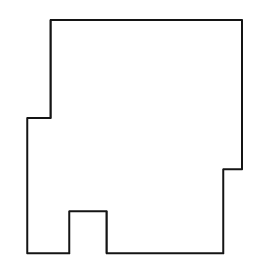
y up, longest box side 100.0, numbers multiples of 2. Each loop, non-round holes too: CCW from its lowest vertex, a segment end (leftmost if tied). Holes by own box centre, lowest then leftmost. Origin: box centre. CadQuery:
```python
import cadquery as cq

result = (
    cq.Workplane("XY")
    .moveTo(-46.0, -50.0)
    .lineTo(-28.0, -50.0)
    .lineTo(-28.0, -32.0)
    .lineTo(-12.0, -32.0)
    .lineTo(-12.0, -50.0)
    .lineTo(38.0, -50.0)
    .lineTo(38.0, -14.0)
    .lineTo(46.0, -14.0)
    .lineTo(46.0, 50.0)
    .lineTo(-36.0, 50.0)
    .lineTo(-36.0, 8.0)
    .lineTo(-46.0, 8.0)
    .close()
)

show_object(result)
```